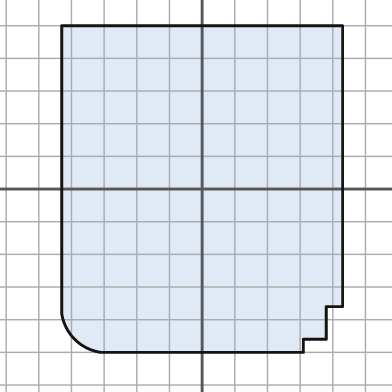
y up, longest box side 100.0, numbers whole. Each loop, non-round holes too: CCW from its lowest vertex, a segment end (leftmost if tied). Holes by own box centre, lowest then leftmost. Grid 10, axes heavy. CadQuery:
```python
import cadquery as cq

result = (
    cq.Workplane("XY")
    .moveTo(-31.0, -50.0)
    .lineTo(31.0, -50.0)
    .lineTo(31.0, -46.0)
    .lineTo(38.0, -46.0)
    .lineTo(38.0, -36.0)
    .lineTo(43.0, -36.0)
    .lineTo(43.0, 50.0)
    .lineTo(-43.0, 50.0)
    .lineTo(-43.0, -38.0)
    .threePointArc((-39.0, -46.0), (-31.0, -50.0))
    .close()
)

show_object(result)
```